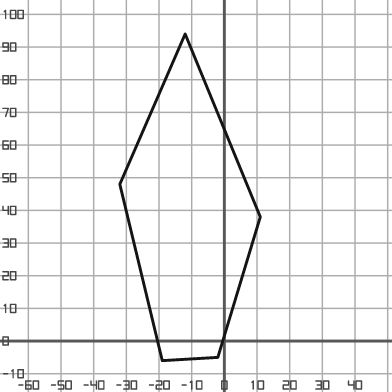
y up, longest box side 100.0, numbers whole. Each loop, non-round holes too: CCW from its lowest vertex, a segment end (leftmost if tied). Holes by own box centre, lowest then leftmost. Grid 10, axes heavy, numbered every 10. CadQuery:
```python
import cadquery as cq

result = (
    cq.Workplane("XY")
    .moveTo(-19.0, -6.0)
    .lineTo(-2.0, -5.0)
    .lineTo(11.0, 38.0)
    .lineTo(-12.0, 94.0)
    .lineTo(-32.0, 48.0)
    .close()
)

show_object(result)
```